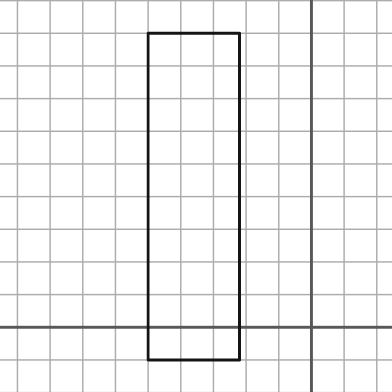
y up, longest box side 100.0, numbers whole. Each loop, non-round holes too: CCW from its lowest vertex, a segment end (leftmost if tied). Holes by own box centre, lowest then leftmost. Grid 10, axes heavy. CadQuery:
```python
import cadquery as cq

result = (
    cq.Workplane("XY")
    .moveTo(-50.0, -10.0)
    .lineTo(-22.0, -10.0)
    .lineTo(-22.0, 90.0)
    .lineTo(-50.0, 90.0)
    .close()
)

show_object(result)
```